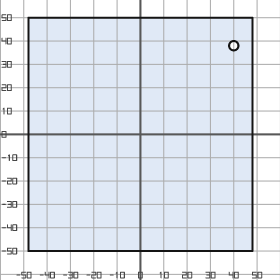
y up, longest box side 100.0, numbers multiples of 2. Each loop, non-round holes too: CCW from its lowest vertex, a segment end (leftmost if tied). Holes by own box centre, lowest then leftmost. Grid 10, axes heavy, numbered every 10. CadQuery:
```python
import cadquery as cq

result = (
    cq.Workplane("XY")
    .moveTo(-48.0, -50.0)
    .lineTo(48.0, -50.0)
    .lineTo(48.0, 50.0)
    .lineTo(-48.0, 50.0)
    .close()
    .moveTo(40.0, 38.0)
    .circle(2.0)
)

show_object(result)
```